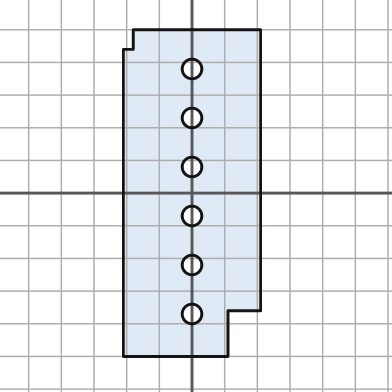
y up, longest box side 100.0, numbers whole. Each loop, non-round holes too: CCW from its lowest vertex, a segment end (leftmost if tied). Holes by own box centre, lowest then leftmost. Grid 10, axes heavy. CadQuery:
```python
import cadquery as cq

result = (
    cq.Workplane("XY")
    .moveTo(-21.0, -50.0)
    .lineTo(11.0, -50.0)
    .lineTo(11.0, -36.0)
    .lineTo(21.0, -36.0)
    .lineTo(21.0, 50.0)
    .lineTo(-18.0, 50.0)
    .lineTo(-18.0, 44.0)
    .lineTo(-21.0, 44.0)
    .close()
    .moveTo(0.0, -37.0)
    .circle(3.0)
    .moveTo(0.0, -22.0)
    .circle(3.0)
    .moveTo(0.0, -7.0)
    .circle(3.0)
    .moveTo(0.0, 8.0)
    .circle(3.0)
    .moveTo(0.0, 23.0)
    .circle(3.0)
    .moveTo(0.0, 38.0)
    .circle(3.0)
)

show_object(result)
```